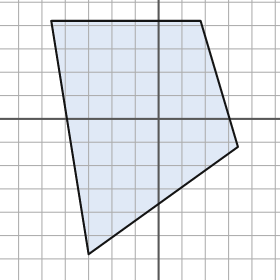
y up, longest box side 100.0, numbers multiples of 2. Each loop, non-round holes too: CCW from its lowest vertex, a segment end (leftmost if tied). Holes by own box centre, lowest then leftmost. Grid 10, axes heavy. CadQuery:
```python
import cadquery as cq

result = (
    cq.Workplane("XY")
    .moveTo(-30.0, -58.0)
    .lineTo(34.0, -12.0)
    .lineTo(18.0, 42.0)
    .lineTo(-46.0, 42.0)
    .close()
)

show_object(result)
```